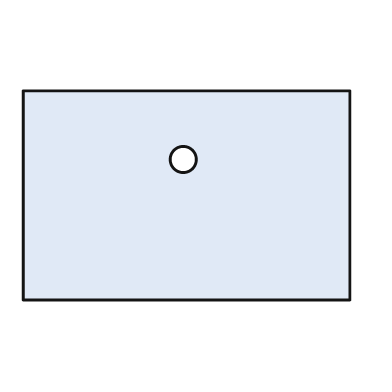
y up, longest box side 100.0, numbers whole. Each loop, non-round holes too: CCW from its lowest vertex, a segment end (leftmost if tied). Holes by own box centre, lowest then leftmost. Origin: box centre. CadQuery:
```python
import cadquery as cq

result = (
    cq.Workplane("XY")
    .moveTo(-50.0, -32.0)
    .lineTo(50.0, -32.0)
    .lineTo(50.0, 32.0)
    .lineTo(-50.0, 32.0)
    .close()
    .moveTo(-1.0, 11.0)
    .circle(4.0)
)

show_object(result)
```